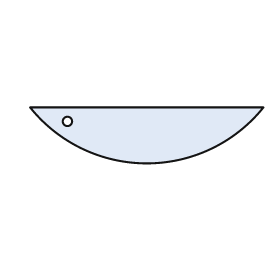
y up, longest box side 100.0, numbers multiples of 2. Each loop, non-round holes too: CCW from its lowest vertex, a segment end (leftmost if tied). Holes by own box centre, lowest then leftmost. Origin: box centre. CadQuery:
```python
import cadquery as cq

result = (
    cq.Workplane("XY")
    .moveTo(-50.0, 12.0)
    .threePointArc((0.0, -12.0), (50.0, 12.0))
    .close()
    .moveTo(-34.0, 6.0)
    .circle(2.0)
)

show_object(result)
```